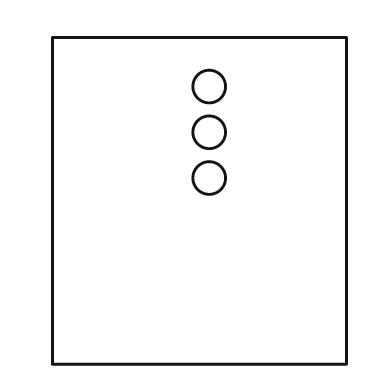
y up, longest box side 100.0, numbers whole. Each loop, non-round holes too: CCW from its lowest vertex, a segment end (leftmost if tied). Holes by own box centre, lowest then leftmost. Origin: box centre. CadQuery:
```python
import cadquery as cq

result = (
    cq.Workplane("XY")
    .moveTo(-45.0, -50.0)
    .lineTo(45.0, -50.0)
    .lineTo(45.0, 50.0)
    .lineTo(-45.0, 50.0)
    .close()
    .moveTo(3.0, 7.0)
    .circle(5.0)
    .moveTo(3.0, 21.0)
    .circle(5.0)
    .moveTo(3.0, 35.0)
    .circle(5.0)
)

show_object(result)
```